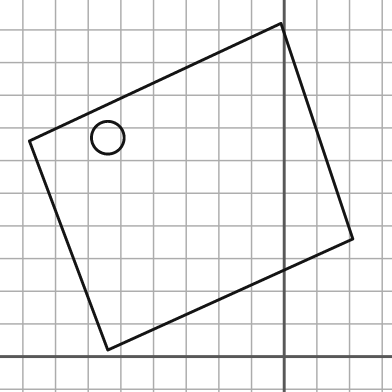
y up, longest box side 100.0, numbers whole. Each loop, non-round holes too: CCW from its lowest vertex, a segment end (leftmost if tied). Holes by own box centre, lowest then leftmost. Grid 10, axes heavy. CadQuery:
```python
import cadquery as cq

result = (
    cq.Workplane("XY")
    .moveTo(-54.0, 2.0)
    .lineTo(21.0, 36.0)
    .lineTo(-1.0, 102.0)
    .lineTo(-78.0, 66.0)
    .close()
    .moveTo(-54.0, 67.0)
    .circle(5.0)
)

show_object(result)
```